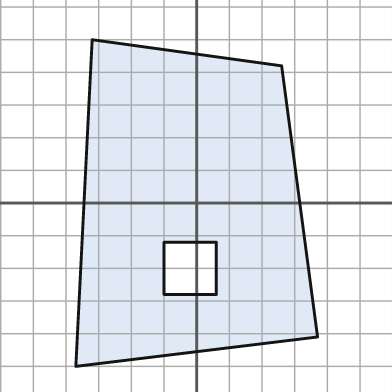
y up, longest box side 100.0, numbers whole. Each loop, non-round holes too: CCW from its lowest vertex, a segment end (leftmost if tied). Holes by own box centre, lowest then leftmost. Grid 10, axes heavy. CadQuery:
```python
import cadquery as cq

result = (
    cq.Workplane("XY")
    .moveTo(-37.0, -50.0)
    .lineTo(37.0, -41.0)
    .lineTo(26.0, 42.0)
    .lineTo(-32.0, 50.0)
    .close()
    .moveTo(-10.0, -28.0)
    .lineTo(6.0, -28.0)
    .lineTo(6.0, -12.0)
    .lineTo(-10.0, -12.0)
    .close()
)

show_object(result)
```